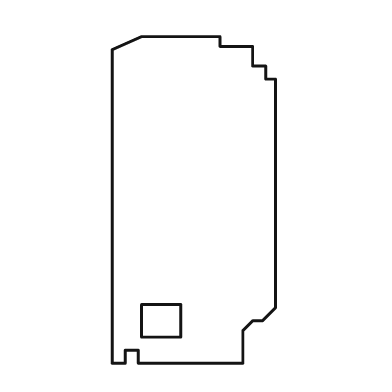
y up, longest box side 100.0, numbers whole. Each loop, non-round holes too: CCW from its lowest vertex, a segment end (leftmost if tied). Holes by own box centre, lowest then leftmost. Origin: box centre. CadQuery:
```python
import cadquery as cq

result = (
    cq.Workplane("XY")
    .moveTo(-25.0, -50.0)
    .lineTo(-21.0, -50.0)
    .lineTo(-21.0, -46.0)
    .lineTo(-17.0, -46.0)
    .lineTo(-17.0, -50.0)
    .lineTo(15.0, -50.0)
    .lineTo(15.0, -40.0)
    .lineTo(18.0, -37.0)
    .lineTo(21.0, -37.0)
    .lineTo(25.0, -33.0)
    .lineTo(25.0, 37.0)
    .lineTo(22.0, 37.0)
    .lineTo(22.0, 41.0)
    .lineTo(18.0, 41.0)
    .lineTo(18.0, 47.0)
    .lineTo(8.0, 47.0)
    .lineTo(8.0, 50.0)
    .lineTo(-16.0, 50.0)
    .lineTo(-25.0, 46.0)
    .close()
    .moveTo(-16.0, -42.0)
    .lineTo(-4.0, -42.0)
    .lineTo(-4.0, -32.0)
    .lineTo(-16.0, -32.0)
    .close()
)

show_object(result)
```